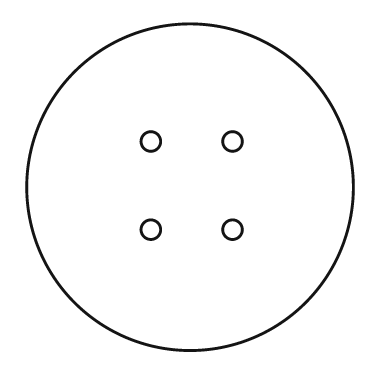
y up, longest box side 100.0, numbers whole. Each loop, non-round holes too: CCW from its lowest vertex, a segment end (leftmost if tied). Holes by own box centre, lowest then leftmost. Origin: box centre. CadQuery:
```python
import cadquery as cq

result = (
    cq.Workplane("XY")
    .moveTo(0.0, 0.0)
    .circle(50.0)
    .moveTo(-12.0, -13.0)
    .circle(3.0)
    .moveTo(13.0, -13.0)
    .circle(3.0)
    .moveTo(-12.0, 14.0)
    .circle(3.0)
    .moveTo(13.0, 14.0)
    .circle(3.0)
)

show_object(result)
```